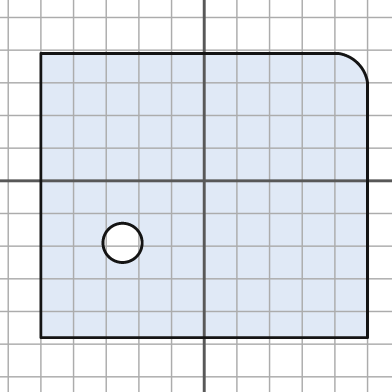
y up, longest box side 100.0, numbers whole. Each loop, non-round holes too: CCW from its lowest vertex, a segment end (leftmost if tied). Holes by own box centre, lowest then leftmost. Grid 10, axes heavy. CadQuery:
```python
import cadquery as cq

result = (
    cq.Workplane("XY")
    .moveTo(-50.0, -48.0)
    .lineTo(50.0, -48.0)
    .lineTo(50.0, 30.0)
    .threePointArc((47.0, 36.0), (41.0, 39.0))
    .lineTo(-50.0, 39.0)
    .close()
    .moveTo(-25.0, -19.0)
    .circle(6.0)
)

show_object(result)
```